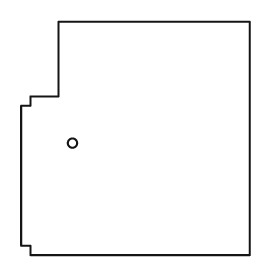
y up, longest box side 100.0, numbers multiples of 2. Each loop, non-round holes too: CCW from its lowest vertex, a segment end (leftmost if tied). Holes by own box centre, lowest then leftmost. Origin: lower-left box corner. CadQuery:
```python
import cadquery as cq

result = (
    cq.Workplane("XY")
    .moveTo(4.0, 0.0)
    .lineTo(98.0, 0.0)
    .lineTo(98.0, 100.0)
    .lineTo(16.0, 100.0)
    .lineTo(16.0, 68.0)
    .lineTo(4.0, 68.0)
    .lineTo(4.0, 64.0)
    .lineTo(0.0, 64.0)
    .lineTo(0.0, 4.0)
    .lineTo(4.0, 4.0)
    .close()
    .moveTo(22.0, 48.0)
    .circle(2.0)
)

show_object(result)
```